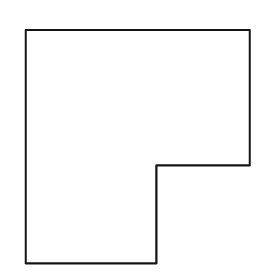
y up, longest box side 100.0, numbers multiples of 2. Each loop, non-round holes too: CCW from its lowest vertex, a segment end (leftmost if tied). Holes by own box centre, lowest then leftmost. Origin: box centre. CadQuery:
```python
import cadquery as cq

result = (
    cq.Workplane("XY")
    .moveTo(-48.0, -50.0)
    .lineTo(8.0, -50.0)
    .lineTo(8.0, -8.0)
    .lineTo(48.0, -8.0)
    .lineTo(48.0, 50.0)
    .lineTo(-48.0, 50.0)
    .close()
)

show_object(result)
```